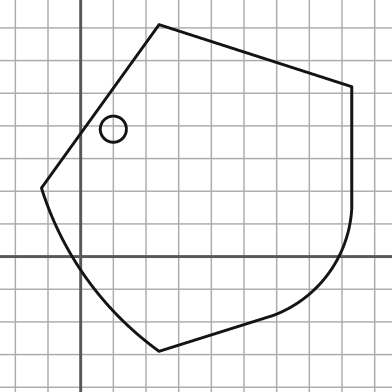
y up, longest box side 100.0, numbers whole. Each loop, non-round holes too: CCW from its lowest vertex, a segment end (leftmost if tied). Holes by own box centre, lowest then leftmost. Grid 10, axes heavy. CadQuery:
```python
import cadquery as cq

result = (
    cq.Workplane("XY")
    .moveTo(24.0, -29.0)
    .lineTo(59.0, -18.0)
    .threePointArc((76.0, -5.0), (83.0, 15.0))
    .lineTo(83.0, 52.0)
    .lineTo(24.0, 71.0)
    .lineTo(-12.0, 21.0)
    .threePointArc((2.0, -7.0), (24.0, -29.0))
    .close()
    .moveTo(10.0, 39.0)
    .circle(4.0)
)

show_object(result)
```